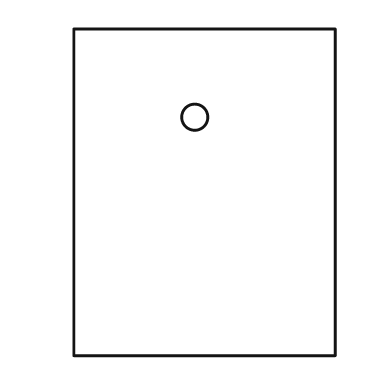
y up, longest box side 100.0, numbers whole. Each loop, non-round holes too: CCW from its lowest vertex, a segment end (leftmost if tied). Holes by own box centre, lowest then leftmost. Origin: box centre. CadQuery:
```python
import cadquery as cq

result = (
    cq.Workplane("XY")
    .moveTo(-40.0, -50.0)
    .lineTo(40.0, -50.0)
    .lineTo(40.0, 50.0)
    .lineTo(-40.0, 50.0)
    .close()
    .moveTo(-3.0, 23.0)
    .circle(4.0)
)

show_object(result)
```